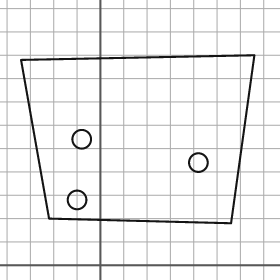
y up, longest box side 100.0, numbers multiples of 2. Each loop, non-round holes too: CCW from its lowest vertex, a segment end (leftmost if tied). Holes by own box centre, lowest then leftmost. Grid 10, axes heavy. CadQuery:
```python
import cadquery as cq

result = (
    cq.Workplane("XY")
    .moveTo(56.0, 18.0)
    .lineTo(66.0, 90.0)
    .lineTo(-34.0, 88.0)
    .lineTo(-22.0, 20.0)
    .close()
    .moveTo(-10.0, 28.0)
    .circle(4.0)
    .moveTo(42.0, 44.0)
    .circle(4.0)
    .moveTo(-8.0, 54.0)
    .circle(4.0)
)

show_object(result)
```